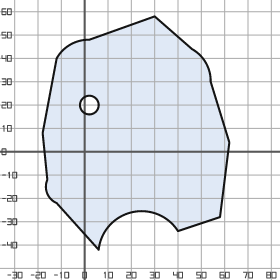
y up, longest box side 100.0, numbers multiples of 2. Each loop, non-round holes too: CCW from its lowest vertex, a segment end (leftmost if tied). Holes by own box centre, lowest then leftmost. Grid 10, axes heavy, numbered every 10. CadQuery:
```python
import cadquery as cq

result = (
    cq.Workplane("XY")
    .moveTo(6.0, -42.0)
    .threePointArc((20.0, -26.0), (40.0, -34.0))
    .lineTo(58.0, -28.0)
    .lineTo(62.0, 4.0)
    .lineTo(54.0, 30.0)
    .threePointArc((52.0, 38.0), (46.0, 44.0))
    .lineTo(30.0, 58.0)
    .lineTo(2.0, 48.0)
    .threePointArc((-6.0, 46.0), (-12.0, 40.0))
    .lineTo(-18.0, 8.0)
    .lineTo(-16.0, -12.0)
    .threePointArc((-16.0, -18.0), (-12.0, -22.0))
    .close()
    .moveTo(2.0, 20.0)
    .circle(4.0)
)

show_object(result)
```